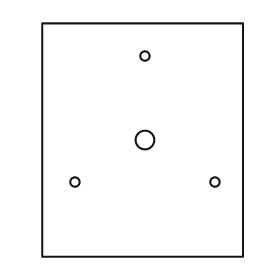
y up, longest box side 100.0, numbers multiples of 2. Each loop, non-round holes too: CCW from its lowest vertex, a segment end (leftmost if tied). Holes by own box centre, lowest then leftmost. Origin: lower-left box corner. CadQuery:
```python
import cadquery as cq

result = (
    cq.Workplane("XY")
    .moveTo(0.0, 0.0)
    .lineTo(86.0, 0.0)
    .lineTo(86.0, 100.0)
    .lineTo(0.0, 100.0)
    .close()
    .moveTo(14.0, 32.0)
    .circle(2.0)
    .moveTo(74.0, 32.0)
    .circle(2.0)
    .moveTo(44.0, 50.0)
    .circle(4.0)
    .moveTo(44.0, 86.0)
    .circle(2.0)
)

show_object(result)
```